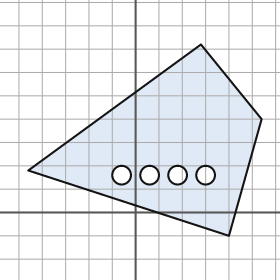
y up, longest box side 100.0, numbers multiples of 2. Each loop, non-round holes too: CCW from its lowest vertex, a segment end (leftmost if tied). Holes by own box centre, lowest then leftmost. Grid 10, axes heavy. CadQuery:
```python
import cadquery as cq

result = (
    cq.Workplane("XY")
    .moveTo(40.0, -10.0)
    .lineTo(54.0, 40.0)
    .lineTo(28.0, 72.0)
    .lineTo(-46.0, 18.0)
    .close()
    .moveTo(-6.0, 16.0)
    .circle(4.0)
    .moveTo(6.0, 16.0)
    .circle(4.0)
    .moveTo(18.0, 16.0)
    .circle(4.0)
    .moveTo(30.0, 16.0)
    .circle(4.0)
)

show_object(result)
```